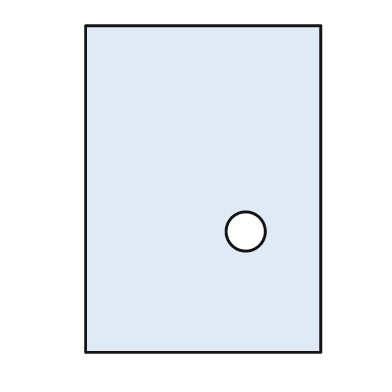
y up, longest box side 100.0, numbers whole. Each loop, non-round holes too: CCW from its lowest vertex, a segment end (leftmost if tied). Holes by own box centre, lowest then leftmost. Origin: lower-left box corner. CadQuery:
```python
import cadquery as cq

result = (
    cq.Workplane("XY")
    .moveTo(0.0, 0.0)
    .lineTo(72.0, 0.0)
    .lineTo(72.0, 100.0)
    .lineTo(0.0, 100.0)
    .close()
    .moveTo(49.0, 37.0)
    .circle(6.0)
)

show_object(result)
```